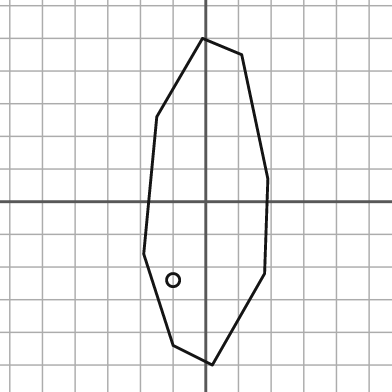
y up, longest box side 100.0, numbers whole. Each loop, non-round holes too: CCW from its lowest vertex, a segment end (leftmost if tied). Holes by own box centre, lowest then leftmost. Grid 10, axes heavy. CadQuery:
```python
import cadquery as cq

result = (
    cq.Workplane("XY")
    .moveTo(2.0, -50.0)
    .lineTo(18.0, -22.0)
    .lineTo(19.0, 7.0)
    .lineTo(11.0, 45.0)
    .lineTo(-1.0, 50.0)
    .lineTo(-15.0, 26.0)
    .lineTo(-19.0, -16.0)
    .lineTo(-10.0, -44.0)
    .close()
    .moveTo(-10.0, -24.0)
    .circle(2.0)
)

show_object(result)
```